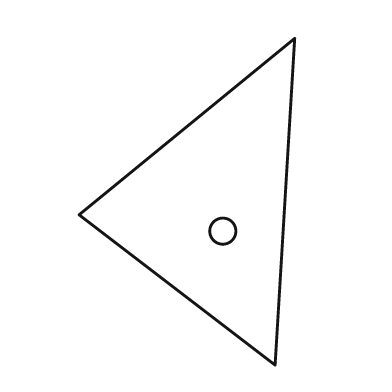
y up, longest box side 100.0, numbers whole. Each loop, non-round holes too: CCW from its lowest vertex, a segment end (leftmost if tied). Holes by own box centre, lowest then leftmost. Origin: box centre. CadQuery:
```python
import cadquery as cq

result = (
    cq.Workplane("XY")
    .moveTo(27.0, -50.0)
    .lineTo(33.0, 50.0)
    .lineTo(-33.0, -4.0)
    .close()
    .moveTo(11.0, -9.0)
    .circle(4.0)
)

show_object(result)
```